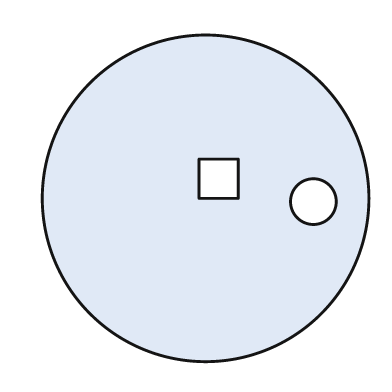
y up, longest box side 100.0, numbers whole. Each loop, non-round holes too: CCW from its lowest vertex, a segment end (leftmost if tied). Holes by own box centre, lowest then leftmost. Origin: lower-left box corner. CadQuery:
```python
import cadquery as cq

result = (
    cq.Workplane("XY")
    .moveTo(50.0, 50.0)
    .circle(50.0)
    .moveTo(83.0, 49.0)
    .circle(7.0)
    .moveTo(48.0, 50.0)
    .lineTo(60.0, 50.0)
    .lineTo(60.0, 62.0)
    .lineTo(48.0, 62.0)
    .close()
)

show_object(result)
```